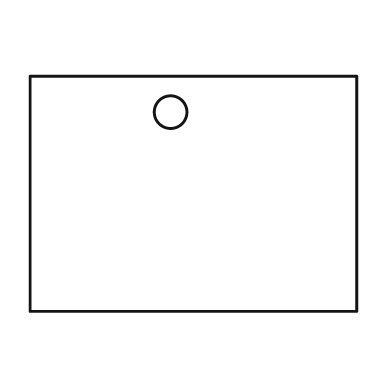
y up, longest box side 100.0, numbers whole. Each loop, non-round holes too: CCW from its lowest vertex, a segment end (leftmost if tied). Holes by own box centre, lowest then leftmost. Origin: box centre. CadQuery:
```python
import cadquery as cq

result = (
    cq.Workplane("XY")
    .moveTo(-50.0, -36.0)
    .lineTo(50.0, -36.0)
    .lineTo(50.0, 36.0)
    .lineTo(-50.0, 36.0)
    .close()
    .moveTo(-7.0, 25.0)
    .circle(5.0)
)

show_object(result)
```